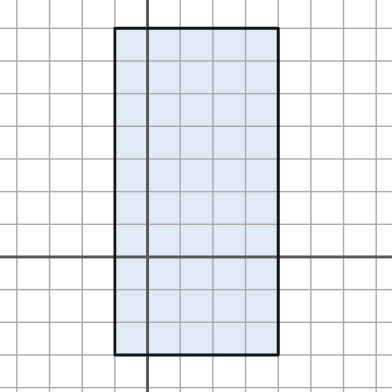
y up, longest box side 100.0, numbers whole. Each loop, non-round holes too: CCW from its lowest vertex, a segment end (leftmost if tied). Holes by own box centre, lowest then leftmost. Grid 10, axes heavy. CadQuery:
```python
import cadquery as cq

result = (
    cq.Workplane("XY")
    .moveTo(-10.0, -30.0)
    .lineTo(40.0, -30.0)
    .lineTo(40.0, 70.0)
    .lineTo(-10.0, 70.0)
    .close()
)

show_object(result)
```